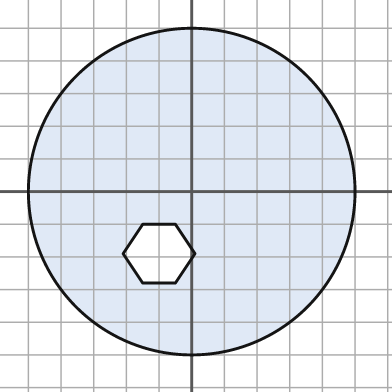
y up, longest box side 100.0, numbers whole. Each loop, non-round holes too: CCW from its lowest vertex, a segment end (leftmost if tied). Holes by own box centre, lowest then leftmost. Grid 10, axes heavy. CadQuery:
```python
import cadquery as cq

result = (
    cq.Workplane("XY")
    .moveTo(0.0, 0.0)
    .circle(50.0)
    .moveTo(-15.0, -28.0)
    .lineTo(-5.0, -28.0)
    .lineTo(1.0, -19.0)
    .lineTo(-5.0, -10.0)
    .lineTo(-15.0, -10.0)
    .lineTo(-21.0, -19.0)
    .close()
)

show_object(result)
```